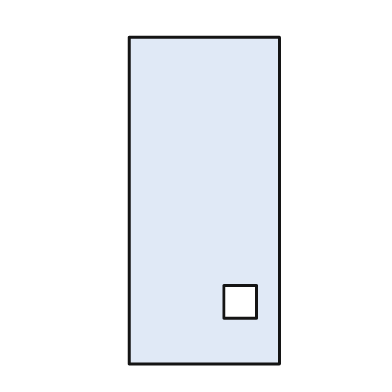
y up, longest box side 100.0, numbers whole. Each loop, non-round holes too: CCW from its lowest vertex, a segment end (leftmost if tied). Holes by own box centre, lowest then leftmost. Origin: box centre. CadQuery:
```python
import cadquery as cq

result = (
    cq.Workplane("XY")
    .moveTo(-23.0, -50.0)
    .lineTo(23.0, -50.0)
    .lineTo(23.0, 50.0)
    .lineTo(-23.0, 50.0)
    .close()
    .moveTo(6.0, -36.0)
    .lineTo(16.0, -36.0)
    .lineTo(16.0, -26.0)
    .lineTo(6.0, -26.0)
    .close()
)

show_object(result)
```